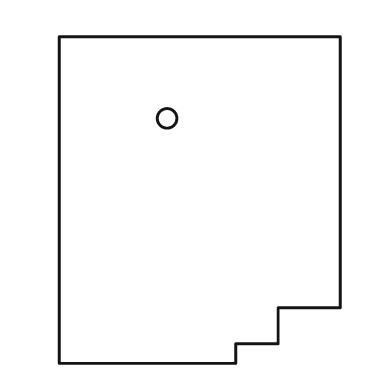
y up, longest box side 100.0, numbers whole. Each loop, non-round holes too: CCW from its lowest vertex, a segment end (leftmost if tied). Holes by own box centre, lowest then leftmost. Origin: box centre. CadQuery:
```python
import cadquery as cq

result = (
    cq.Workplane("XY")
    .moveTo(-43.0, -50.0)
    .lineTo(11.0, -50.0)
    .lineTo(11.0, -44.0)
    .lineTo(24.0, -44.0)
    .lineTo(24.0, -33.0)
    .lineTo(43.0, -33.0)
    .lineTo(43.0, 50.0)
    .lineTo(-43.0, 50.0)
    .close()
    .moveTo(-10.0, 25.0)
    .circle(3.0)
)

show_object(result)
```